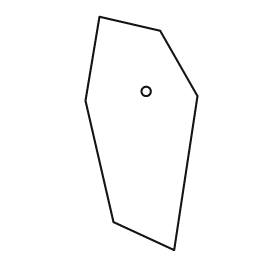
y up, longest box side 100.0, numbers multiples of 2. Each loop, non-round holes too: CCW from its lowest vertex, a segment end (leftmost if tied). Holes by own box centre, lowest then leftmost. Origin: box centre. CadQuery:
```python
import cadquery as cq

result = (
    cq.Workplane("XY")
    .moveTo(14.0, -50.0)
    .lineTo(24.0, 16.0)
    .lineTo(8.0, 44.0)
    .lineTo(-18.0, 50.0)
    .lineTo(-24.0, 14.0)
    .lineTo(-12.0, -38.0)
    .close()
    .moveTo(2.0, 18.0)
    .circle(2.0)
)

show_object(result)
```